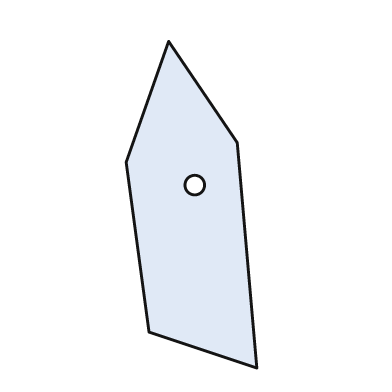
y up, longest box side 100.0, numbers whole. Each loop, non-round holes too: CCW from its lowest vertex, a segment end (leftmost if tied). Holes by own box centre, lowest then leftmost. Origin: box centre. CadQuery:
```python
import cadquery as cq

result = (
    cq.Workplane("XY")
    .moveTo(20.0, -50.0)
    .lineTo(14.0, 19.0)
    .lineTo(-7.0, 50.0)
    .lineTo(-20.0, 13.0)
    .lineTo(-13.0, -39.0)
    .close()
    .moveTo(1.0, 6.0)
    .circle(3.0)
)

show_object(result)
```